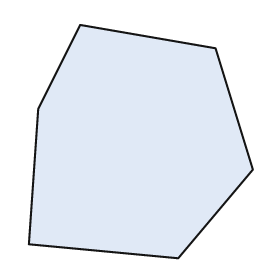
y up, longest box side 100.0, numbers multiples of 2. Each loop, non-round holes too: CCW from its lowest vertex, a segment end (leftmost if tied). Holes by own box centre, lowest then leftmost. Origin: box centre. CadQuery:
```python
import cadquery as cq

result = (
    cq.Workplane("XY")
    .moveTo(16.0, -50.0)
    .lineTo(48.0, -12.0)
    .lineTo(32.0, 40.0)
    .lineTo(-26.0, 50.0)
    .lineTo(-44.0, 14.0)
    .lineTo(-48.0, -44.0)
    .close()
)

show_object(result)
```